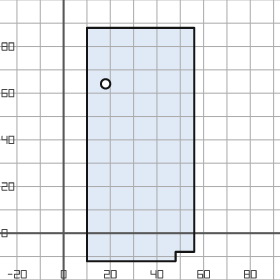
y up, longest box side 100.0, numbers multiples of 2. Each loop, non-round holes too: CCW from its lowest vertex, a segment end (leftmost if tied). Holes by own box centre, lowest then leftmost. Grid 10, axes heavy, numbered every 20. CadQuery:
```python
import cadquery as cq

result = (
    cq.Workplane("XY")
    .moveTo(10.0, -12.0)
    .lineTo(48.0, -12.0)
    .lineTo(48.0, -8.0)
    .lineTo(56.0, -8.0)
    .lineTo(56.0, 88.0)
    .lineTo(10.0, 88.0)
    .close()
    .moveTo(18.0, 64.0)
    .circle(2.0)
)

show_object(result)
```